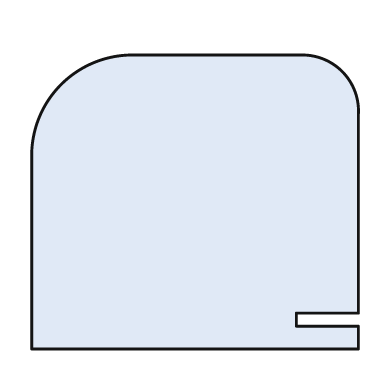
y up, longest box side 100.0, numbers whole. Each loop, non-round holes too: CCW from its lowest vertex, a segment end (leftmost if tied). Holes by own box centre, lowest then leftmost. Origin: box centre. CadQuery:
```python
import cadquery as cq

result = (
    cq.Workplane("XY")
    .moveTo(-50.0, -45.0)
    .lineTo(50.0, -45.0)
    .lineTo(50.0, -38.0)
    .lineTo(31.0, -38.0)
    .lineTo(31.0, -34.0)
    .lineTo(50.0, -34.0)
    .lineTo(50.0, 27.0)
    .threePointArc((45.0, 40.0), (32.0, 45.0))
    .lineTo(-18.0, 45.0)
    .threePointArc((-41.0, 36.0), (-50.0, 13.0))
    .close()
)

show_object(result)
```